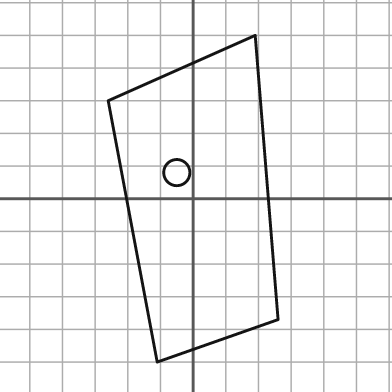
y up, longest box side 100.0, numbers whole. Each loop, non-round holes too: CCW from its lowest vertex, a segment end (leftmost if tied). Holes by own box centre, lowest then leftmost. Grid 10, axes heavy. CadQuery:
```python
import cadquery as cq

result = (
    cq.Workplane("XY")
    .moveTo(-11.0, -50.0)
    .lineTo(26.0, -37.0)
    .lineTo(19.0, 50.0)
    .lineTo(-26.0, 30.0)
    .close()
    .moveTo(-5.0, 8.0)
    .circle(4.0)
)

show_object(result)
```